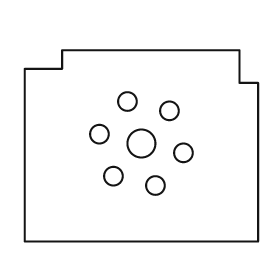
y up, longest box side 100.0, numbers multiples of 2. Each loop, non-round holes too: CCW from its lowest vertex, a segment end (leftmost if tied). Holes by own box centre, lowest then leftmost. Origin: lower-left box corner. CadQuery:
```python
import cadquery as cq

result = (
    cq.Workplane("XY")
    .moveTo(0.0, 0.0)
    .lineTo(100.0, 0.0)
    .lineTo(100.0, 68.0)
    .lineTo(92.0, 68.0)
    .lineTo(92.0, 82.0)
    .lineTo(16.0, 82.0)
    .lineTo(16.0, 74.0)
    .lineTo(0.0, 74.0)
    .close()
    .moveTo(56.0, 24.0)
    .circle(4.0)
    .moveTo(38.0, 28.0)
    .circle(4.0)
    .moveTo(68.0, 38.0)
    .circle(4.0)
    .moveTo(50.0, 42.0)
    .circle(6.0)
    .moveTo(32.0, 46.0)
    .circle(4.0)
    .moveTo(62.0, 56.0)
    .circle(4.0)
    .moveTo(44.0, 60.0)
    .circle(4.0)
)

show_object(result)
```